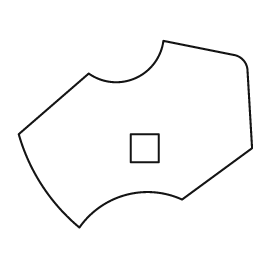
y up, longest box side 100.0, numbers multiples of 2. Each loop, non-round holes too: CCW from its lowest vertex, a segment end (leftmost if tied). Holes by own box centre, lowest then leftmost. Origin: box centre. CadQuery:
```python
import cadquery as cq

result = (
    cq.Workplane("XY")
    .moveTo(-24.0, -40.0)
    .threePointArc((-4.0, -26.0), (20.0, -28.0))
    .lineTo(50.0, -6.0)
    .lineTo(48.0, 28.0)
    .threePointArc((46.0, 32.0), (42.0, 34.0))
    .lineTo(12.0, 40.0)
    .threePointArc((0.0, 24.0), (-20.0, 26.0))
    .lineTo(-50.0, 0.0)
    .threePointArc((-40.0, -22.0), (-24.0, -40.0))
    .close()
    .moveTo(-2.0, -12.0)
    .lineTo(10.0, -12.0)
    .lineTo(10.0, 0.0)
    .lineTo(-2.0, 0.0)
    .close()
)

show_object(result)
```